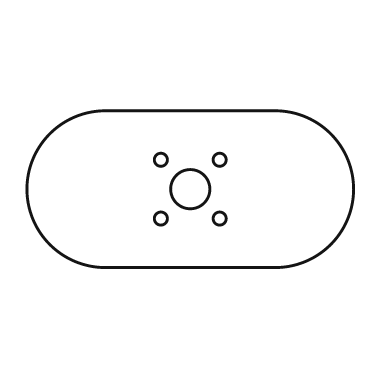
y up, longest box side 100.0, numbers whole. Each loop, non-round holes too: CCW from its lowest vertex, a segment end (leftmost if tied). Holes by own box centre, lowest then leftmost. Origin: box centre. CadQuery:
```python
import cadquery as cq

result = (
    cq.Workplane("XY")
    .moveTo(-26.0, -24.0)
    .lineTo(26.0, -24.0)
    .threePointArc((50.0, 0.0), (26.0, 24.0))
    .lineTo(-26.0, 24.0)
    .threePointArc((-50.0, 0.0), (-26.0, -24.0))
    .close()
    .moveTo(-9.0, -9.0)
    .circle(2.0)
    .moveTo(9.0, -9.0)
    .circle(2.0)
    .moveTo(0.0, 0.0)
    .circle(6.0)
    .moveTo(-9.0, 9.0)
    .circle(2.0)
    .moveTo(9.0, 9.0)
    .circle(2.0)
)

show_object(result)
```